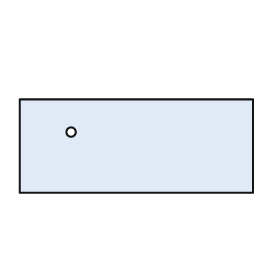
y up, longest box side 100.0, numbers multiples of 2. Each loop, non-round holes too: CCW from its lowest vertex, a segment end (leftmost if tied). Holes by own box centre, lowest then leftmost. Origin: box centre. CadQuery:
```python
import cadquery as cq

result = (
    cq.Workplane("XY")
    .moveTo(-50.0, -20.0)
    .lineTo(50.0, -20.0)
    .lineTo(50.0, 20.0)
    .lineTo(-50.0, 20.0)
    .close()
    .moveTo(-28.0, 6.0)
    .circle(2.0)
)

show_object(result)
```